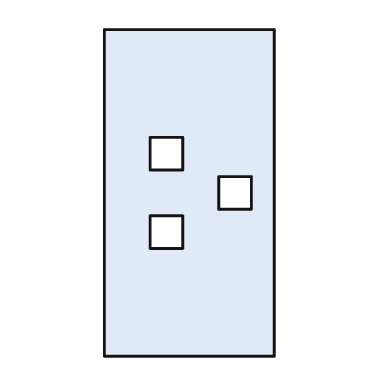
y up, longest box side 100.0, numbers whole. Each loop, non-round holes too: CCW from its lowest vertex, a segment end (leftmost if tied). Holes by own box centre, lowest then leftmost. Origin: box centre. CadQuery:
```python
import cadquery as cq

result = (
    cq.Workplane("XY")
    .moveTo(-26.0, -50.0)
    .lineTo(26.0, -50.0)
    .lineTo(26.0, 50.0)
    .lineTo(-26.0, 50.0)
    .close()
    .moveTo(-12.0, -17.0)
    .lineTo(-2.0, -17.0)
    .lineTo(-2.0, -7.0)
    .lineTo(-12.0, -7.0)
    .close()
    .moveTo(9.0, -5.0)
    .lineTo(19.0, -5.0)
    .lineTo(19.0, 5.0)
    .lineTo(9.0, 5.0)
    .close()
    .moveTo(-12.0, 7.0)
    .lineTo(-2.0, 7.0)
    .lineTo(-2.0, 17.0)
    .lineTo(-12.0, 17.0)
    .close()
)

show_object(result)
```